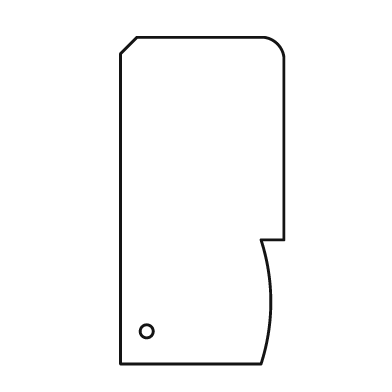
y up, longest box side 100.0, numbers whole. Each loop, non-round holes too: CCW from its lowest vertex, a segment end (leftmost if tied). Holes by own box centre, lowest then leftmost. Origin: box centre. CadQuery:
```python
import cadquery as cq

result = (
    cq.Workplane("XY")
    .moveTo(-25.0, -50.0)
    .lineTo(18.0, -50.0)
    .threePointArc((21.0, -31.0), (18.0, -12.0))
    .lineTo(25.0, -12.0)
    .lineTo(25.0, 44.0)
    .threePointArc((23.0, 48.0), (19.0, 50.0))
    .lineTo(-20.0, 50.0)
    .lineTo(-25.0, 45.0)
    .close()
    .moveTo(-17.0, -40.0)
    .circle(2.0)
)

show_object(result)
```